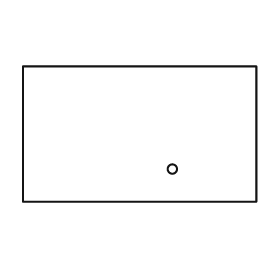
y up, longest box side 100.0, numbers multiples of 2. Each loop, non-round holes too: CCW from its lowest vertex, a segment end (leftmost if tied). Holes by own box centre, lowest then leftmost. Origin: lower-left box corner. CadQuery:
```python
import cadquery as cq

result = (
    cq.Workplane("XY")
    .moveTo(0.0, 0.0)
    .lineTo(100.0, 0.0)
    .lineTo(100.0, 58.0)
    .lineTo(0.0, 58.0)
    .close()
    .moveTo(64.0, 14.0)
    .circle(2.0)
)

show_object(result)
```